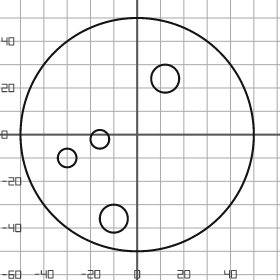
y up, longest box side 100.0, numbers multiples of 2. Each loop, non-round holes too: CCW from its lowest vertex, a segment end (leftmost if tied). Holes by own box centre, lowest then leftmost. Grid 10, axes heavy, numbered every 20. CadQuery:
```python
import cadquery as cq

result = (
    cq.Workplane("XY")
    .moveTo(0.0, 0.0)
    .circle(50.0)
    .moveTo(-10.0, -36.0)
    .circle(6.0)
    .moveTo(-30.0, -10.0)
    .circle(4.0)
    .moveTo(-16.0, -2.0)
    .circle(4.0)
    .moveTo(12.0, 24.0)
    .circle(6.0)
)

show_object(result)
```